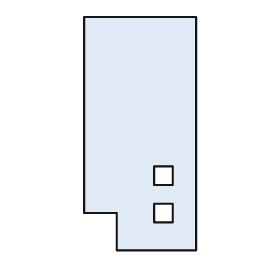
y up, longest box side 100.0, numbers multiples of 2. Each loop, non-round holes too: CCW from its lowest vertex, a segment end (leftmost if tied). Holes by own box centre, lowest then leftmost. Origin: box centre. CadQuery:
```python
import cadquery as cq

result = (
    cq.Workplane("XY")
    .moveTo(-10.0, -50.0)
    .lineTo(24.0, -50.0)
    .lineTo(24.0, 50.0)
    .lineTo(-24.0, 50.0)
    .lineTo(-24.0, -34.0)
    .lineTo(-10.0, -34.0)
    .close()
    .moveTo(6.0, -38.0)
    .lineTo(14.0, -38.0)
    .lineTo(14.0, -30.0)
    .lineTo(6.0, -30.0)
    .close()
    .moveTo(6.0, -22.0)
    .lineTo(14.0, -22.0)
    .lineTo(14.0, -14.0)
    .lineTo(6.0, -14.0)
    .close()
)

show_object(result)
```